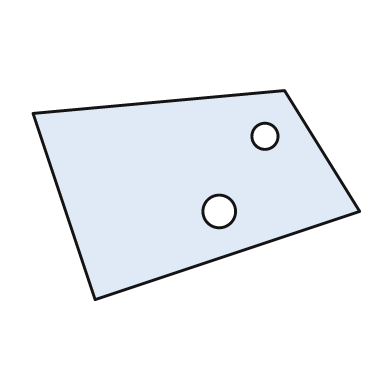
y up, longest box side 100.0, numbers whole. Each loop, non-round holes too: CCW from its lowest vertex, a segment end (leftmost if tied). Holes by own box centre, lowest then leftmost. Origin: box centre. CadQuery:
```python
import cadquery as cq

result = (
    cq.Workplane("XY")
    .moveTo(-31.0, -32.0)
    .lineTo(50.0, -5.0)
    .lineTo(27.0, 32.0)
    .lineTo(-50.0, 25.0)
    .close()
    .moveTo(7.0, -5.0)
    .circle(5.0)
    .moveTo(21.0, 18.0)
    .circle(4.0)
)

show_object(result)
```